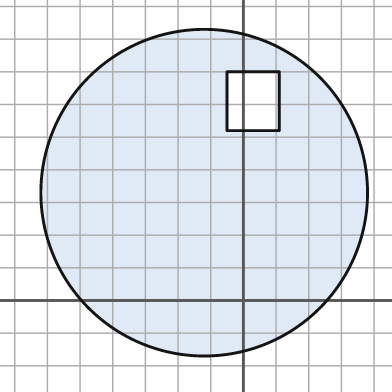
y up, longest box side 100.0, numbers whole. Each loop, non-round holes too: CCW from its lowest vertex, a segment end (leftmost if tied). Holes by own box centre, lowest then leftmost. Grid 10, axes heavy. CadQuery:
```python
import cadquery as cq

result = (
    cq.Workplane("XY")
    .moveTo(-12.0, 33.0)
    .circle(50.0)
    .moveTo(-5.0, 52.0)
    .lineTo(11.0, 52.0)
    .lineTo(11.0, 70.0)
    .lineTo(-5.0, 70.0)
    .close()
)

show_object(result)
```